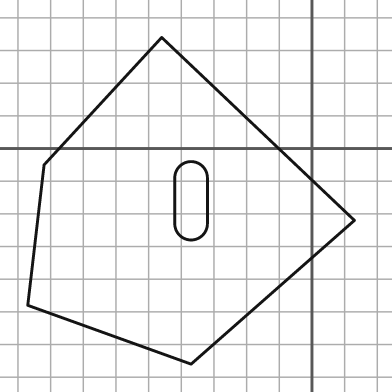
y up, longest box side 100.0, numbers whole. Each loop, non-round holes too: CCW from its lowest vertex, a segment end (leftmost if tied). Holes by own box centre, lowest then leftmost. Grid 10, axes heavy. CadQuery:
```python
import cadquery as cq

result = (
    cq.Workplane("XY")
    .moveTo(-37.0, -66.0)
    .lineTo(13.0, -22.0)
    .lineTo(-46.0, 34.0)
    .lineTo(-82.0, -5.0)
    .lineTo(-87.0, -48.0)
    .close()
    .moveTo(-42.0, -23.0)
    .threePointArc((-37.0, -28.0), (-32.0, -23.0))
    .lineTo(-32.0, -9.0)
    .threePointArc((-37.0, -4.0), (-42.0, -9.0))
    .close()
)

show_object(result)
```